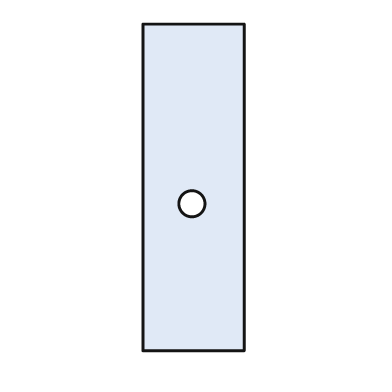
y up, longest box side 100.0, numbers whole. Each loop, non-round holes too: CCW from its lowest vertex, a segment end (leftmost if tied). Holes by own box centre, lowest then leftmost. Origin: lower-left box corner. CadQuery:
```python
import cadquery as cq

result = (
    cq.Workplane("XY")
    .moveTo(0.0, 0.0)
    .lineTo(31.0, 0.0)
    .lineTo(31.0, 100.0)
    .lineTo(0.0, 100.0)
    .close()
    .moveTo(15.0, 45.0)
    .circle(4.0)
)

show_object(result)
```